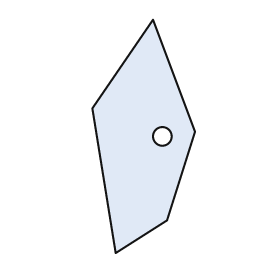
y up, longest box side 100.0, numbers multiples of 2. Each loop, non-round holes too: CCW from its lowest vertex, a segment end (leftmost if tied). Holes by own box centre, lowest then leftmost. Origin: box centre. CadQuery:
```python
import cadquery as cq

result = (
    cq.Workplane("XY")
    .moveTo(-12.0, -50.0)
    .lineTo(10.0, -36.0)
    .lineTo(22.0, 2.0)
    .lineTo(4.0, 50.0)
    .lineTo(-22.0, 12.0)
    .close()
    .moveTo(8.0, 0.0)
    .circle(4.0)
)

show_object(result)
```